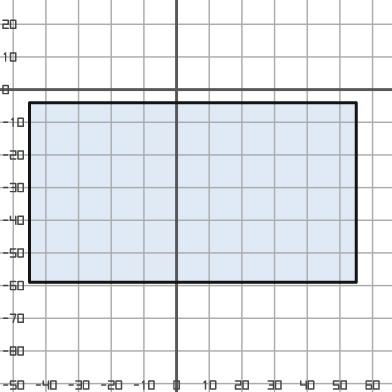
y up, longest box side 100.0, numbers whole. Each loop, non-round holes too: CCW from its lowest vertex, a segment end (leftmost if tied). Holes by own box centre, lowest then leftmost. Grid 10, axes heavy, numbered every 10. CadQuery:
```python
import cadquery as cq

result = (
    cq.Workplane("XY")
    .moveTo(-45.0, -59.0)
    .lineTo(55.0, -59.0)
    .lineTo(55.0, -4.0)
    .lineTo(-45.0, -4.0)
    .close()
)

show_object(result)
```